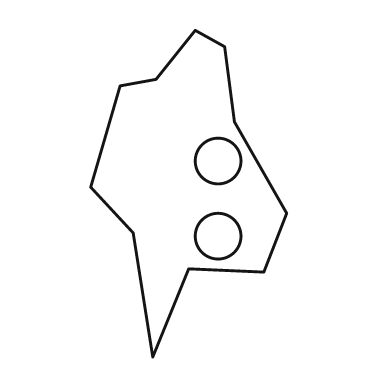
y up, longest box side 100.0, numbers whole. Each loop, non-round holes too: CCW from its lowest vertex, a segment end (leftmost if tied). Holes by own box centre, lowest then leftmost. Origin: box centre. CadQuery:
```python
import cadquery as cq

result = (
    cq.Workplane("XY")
    .moveTo(-11.0, -50.0)
    .lineTo(0.0, -23.0)
    .lineTo(23.0, -24.0)
    .lineTo(30.0, -6.0)
    .lineTo(14.0, 22.0)
    .lineTo(11.0, 45.0)
    .lineTo(2.0, 50.0)
    .lineTo(-10.0, 35.0)
    .lineTo(-21.0, 33.0)
    .lineTo(-30.0, 2.0)
    .lineTo(-17.0, -12.0)
    .close()
    .moveTo(9.0, -13.0)
    .circle(7.0)
    .moveTo(9.0, 10.0)
    .circle(7.0)
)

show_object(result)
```